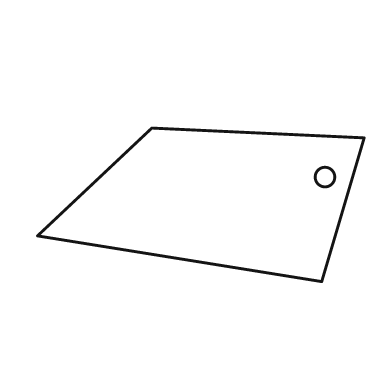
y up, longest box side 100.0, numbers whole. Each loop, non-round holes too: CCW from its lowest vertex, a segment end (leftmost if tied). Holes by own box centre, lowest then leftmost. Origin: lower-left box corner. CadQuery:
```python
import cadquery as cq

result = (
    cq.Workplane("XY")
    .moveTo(87.0, 0.0)
    .lineTo(100.0, 44.0)
    .lineTo(35.0, 47.0)
    .lineTo(0.0, 14.0)
    .close()
    .moveTo(88.0, 32.0)
    .circle(3.0)
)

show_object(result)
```